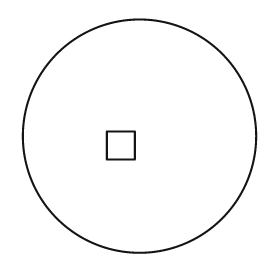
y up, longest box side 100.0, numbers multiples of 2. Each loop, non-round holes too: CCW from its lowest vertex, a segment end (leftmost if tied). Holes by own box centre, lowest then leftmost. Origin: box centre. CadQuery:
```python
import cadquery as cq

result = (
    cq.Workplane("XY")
    .moveTo(0.0, 0.0)
    .circle(50.0)
    .moveTo(-14.0, -10.0)
    .lineTo(-2.0, -10.0)
    .lineTo(-2.0, 2.0)
    .lineTo(-14.0, 2.0)
    .close()
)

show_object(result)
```